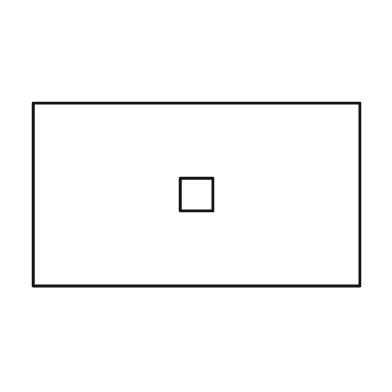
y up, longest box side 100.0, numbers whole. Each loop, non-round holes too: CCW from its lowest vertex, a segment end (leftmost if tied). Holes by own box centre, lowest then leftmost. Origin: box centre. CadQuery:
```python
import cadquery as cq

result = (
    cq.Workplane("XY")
    .moveTo(-50.0, -28.0)
    .lineTo(50.0, -28.0)
    .lineTo(50.0, 28.0)
    .lineTo(-50.0, 28.0)
    .close()
    .moveTo(-5.0, -5.0)
    .lineTo(5.0, -5.0)
    .lineTo(5.0, 5.0)
    .lineTo(-5.0, 5.0)
    .close()
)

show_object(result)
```